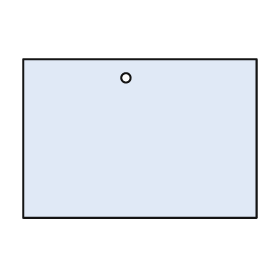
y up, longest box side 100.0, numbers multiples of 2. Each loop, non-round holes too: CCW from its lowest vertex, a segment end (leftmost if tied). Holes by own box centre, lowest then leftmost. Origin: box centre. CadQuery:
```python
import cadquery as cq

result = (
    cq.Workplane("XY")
    .moveTo(-50.0, -34.0)
    .lineTo(50.0, -34.0)
    .lineTo(50.0, 34.0)
    .lineTo(-50.0, 34.0)
    .close()
    .moveTo(-6.0, 26.0)
    .circle(2.0)
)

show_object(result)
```